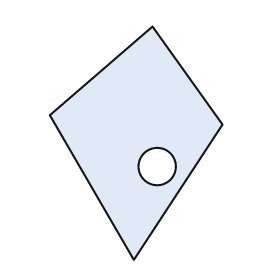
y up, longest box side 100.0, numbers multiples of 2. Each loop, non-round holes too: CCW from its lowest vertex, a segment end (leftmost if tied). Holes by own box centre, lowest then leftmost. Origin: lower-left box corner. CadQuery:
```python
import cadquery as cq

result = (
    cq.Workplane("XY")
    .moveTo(36.0, 0.0)
    .lineTo(74.0, 58.0)
    .lineTo(44.0, 100.0)
    .lineTo(0.0, 62.0)
    .close()
    .moveTo(46.0, 40.0)
    .circle(8.0)
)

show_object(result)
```